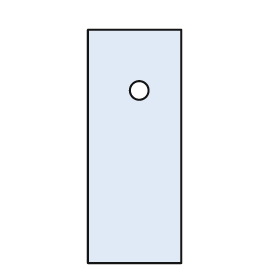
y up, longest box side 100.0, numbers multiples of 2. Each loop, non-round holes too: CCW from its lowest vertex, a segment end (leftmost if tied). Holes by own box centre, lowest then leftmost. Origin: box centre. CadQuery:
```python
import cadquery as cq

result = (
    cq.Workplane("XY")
    .moveTo(-20.0, -50.0)
    .lineTo(20.0, -50.0)
    .lineTo(20.0, 50.0)
    .lineTo(-20.0, 50.0)
    .close()
    .moveTo(2.0, 24.0)
    .circle(4.0)
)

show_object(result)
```